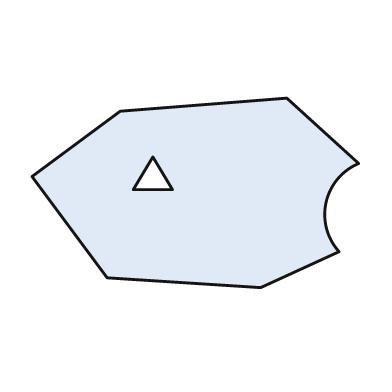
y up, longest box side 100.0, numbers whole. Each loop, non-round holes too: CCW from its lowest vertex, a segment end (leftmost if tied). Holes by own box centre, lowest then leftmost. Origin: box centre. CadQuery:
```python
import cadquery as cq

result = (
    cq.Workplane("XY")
    .moveTo(20.0, -29.0)
    .lineTo(44.0, -18.0)
    .threePointArc((40.0, -3.0), (50.0, 9.0))
    .lineTo(28.0, 29.0)
    .lineTo(-23.0, 25.0)
    .lineTo(-50.0, 5.0)
    .lineTo(-27.0, -26.0)
    .close()
    .moveTo(-19.0, 1.0)
    .lineTo(-7.0, 1.0)
    .lineTo(-13.0, 11.0)
    .close()
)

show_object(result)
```